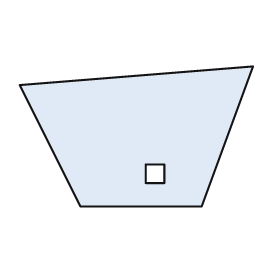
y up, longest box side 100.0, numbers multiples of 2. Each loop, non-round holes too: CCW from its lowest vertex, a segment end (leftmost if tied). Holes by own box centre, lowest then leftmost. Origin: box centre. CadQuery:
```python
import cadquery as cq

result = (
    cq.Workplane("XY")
    .moveTo(-24.0, -30.0)
    .lineTo(28.0, -30.0)
    .lineTo(50.0, 30.0)
    .lineTo(-50.0, 22.0)
    .close()
    .moveTo(4.0, -20.0)
    .lineTo(12.0, -20.0)
    .lineTo(12.0, -12.0)
    .lineTo(4.0, -12.0)
    .close()
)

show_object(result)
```